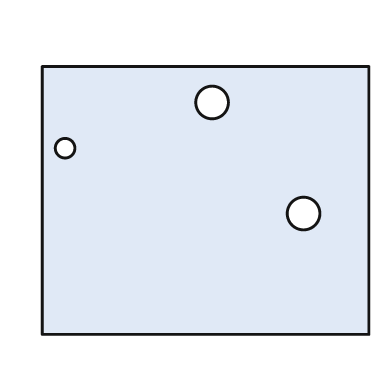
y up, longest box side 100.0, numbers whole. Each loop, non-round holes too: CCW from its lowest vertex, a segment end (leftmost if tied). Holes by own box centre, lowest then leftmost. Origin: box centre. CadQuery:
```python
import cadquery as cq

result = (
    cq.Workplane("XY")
    .moveTo(-50.0, -41.0)
    .lineTo(50.0, -41.0)
    .lineTo(50.0, 41.0)
    .lineTo(-50.0, 41.0)
    .close()
    .moveTo(30.0, -4.0)
    .circle(5.0)
    .moveTo(-43.0, 16.0)
    .circle(3.0)
    .moveTo(2.0, 30.0)
    .circle(5.0)
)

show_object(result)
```